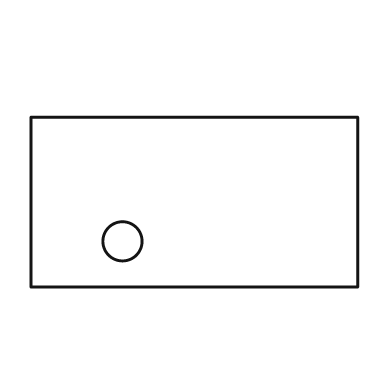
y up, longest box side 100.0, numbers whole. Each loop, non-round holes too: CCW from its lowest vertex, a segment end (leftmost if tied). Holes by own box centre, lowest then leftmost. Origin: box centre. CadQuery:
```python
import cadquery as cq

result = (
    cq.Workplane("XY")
    .moveTo(-50.0, -26.0)
    .lineTo(50.0, -26.0)
    .lineTo(50.0, 26.0)
    .lineTo(-50.0, 26.0)
    .close()
    .moveTo(-22.0, -12.0)
    .circle(6.0)
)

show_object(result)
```